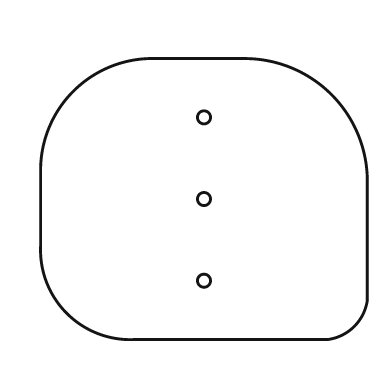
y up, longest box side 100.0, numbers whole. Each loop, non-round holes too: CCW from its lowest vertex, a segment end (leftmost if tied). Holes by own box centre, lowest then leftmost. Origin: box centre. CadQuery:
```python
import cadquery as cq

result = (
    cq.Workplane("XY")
    .moveTo(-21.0, -43.0)
    .lineTo(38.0, -43.0)
    .threePointArc((46.0, -39.0), (50.0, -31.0))
    .lineTo(50.0, 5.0)
    .threePointArc((39.0, 32.0), (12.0, 43.0))
    .lineTo(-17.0, 43.0)
    .threePointArc((-40.0, 33.0), (-50.0, 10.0))
    .lineTo(-50.0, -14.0)
    .threePointArc((-42.0, -35.0), (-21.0, -43.0))
    .close()
    .moveTo(0.0, -25.0)
    .circle(2.0)
    .moveTo(0.0, 0.0)
    .circle(2.0)
    .moveTo(0.0, 25.0)
    .circle(2.0)
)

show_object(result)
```